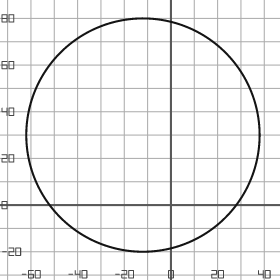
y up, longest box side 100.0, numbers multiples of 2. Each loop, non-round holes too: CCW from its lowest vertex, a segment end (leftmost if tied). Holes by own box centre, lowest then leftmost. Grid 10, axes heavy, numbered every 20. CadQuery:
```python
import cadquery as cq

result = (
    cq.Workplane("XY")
    .moveTo(-12.0, 30.0)
    .circle(50.0)
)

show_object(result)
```